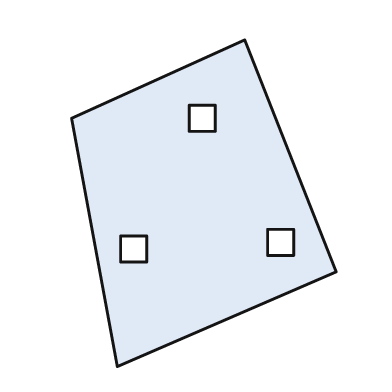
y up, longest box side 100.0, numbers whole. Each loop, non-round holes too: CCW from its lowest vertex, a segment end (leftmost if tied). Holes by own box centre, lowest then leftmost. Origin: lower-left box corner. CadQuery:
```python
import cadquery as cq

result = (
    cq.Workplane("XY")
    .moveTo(14.0, 0.0)
    .lineTo(81.0, 29.0)
    .lineTo(53.0, 100.0)
    .lineTo(0.0, 76.0)
    .close()
    .moveTo(15.0, 32.0)
    .lineTo(23.0, 32.0)
    .lineTo(23.0, 40.0)
    .lineTo(15.0, 40.0)
    .close()
    .moveTo(60.0, 34.0)
    .lineTo(68.0, 34.0)
    .lineTo(68.0, 42.0)
    .lineTo(60.0, 42.0)
    .close()
    .moveTo(36.0, 72.0)
    .lineTo(44.0, 72.0)
    .lineTo(44.0, 80.0)
    .lineTo(36.0, 80.0)
    .close()
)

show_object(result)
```